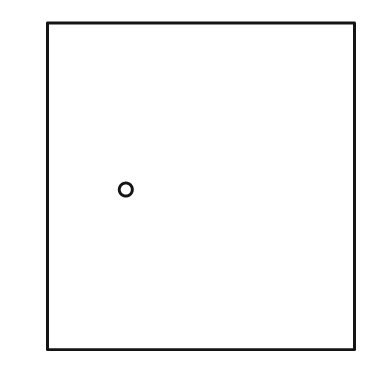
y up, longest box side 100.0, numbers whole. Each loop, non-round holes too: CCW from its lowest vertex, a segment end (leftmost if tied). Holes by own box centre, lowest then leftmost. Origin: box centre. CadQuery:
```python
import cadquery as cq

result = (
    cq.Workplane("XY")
    .moveTo(-47.0, -50.0)
    .lineTo(47.0, -50.0)
    .lineTo(47.0, 50.0)
    .lineTo(-47.0, 50.0)
    .close()
    .moveTo(-23.0, -1.0)
    .circle(2.0)
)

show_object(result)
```